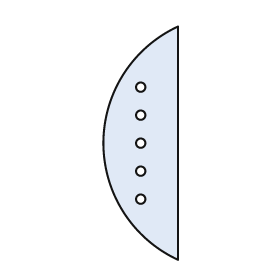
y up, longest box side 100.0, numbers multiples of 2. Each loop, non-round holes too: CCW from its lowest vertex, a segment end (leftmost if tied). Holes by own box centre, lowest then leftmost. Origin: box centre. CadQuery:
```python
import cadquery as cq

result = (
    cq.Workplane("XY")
    .moveTo(16.0, -50.0)
    .lineTo(16.0, 50.0)
    .threePointArc((-16.0, 0.0), (16.0, -50.0))
    .close()
    .moveTo(0.0, -24.0)
    .circle(2.0)
    .moveTo(0.0, -12.0)
    .circle(2.0)
    .moveTo(0.0, 0.0)
    .circle(2.0)
    .moveTo(0.0, 12.0)
    .circle(2.0)
    .moveTo(0.0, 24.0)
    .circle(2.0)
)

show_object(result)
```